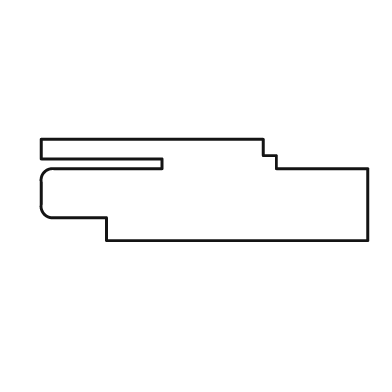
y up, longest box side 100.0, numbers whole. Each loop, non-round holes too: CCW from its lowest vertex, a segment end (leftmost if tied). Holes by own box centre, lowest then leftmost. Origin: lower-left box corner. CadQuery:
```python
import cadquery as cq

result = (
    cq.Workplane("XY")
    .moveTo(20.0, 0.0)
    .lineTo(100.0, 0.0)
    .lineTo(100.0, 22.0)
    .lineTo(72.0, 22.0)
    .lineTo(72.0, 26.0)
    .lineTo(68.0, 26.0)
    .lineTo(68.0, 31.0)
    .lineTo(0.0, 31.0)
    .lineTo(0.0, 25.0)
    .lineTo(37.0, 25.0)
    .lineTo(37.0, 22.0)
    .lineTo(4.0, 22.0)
    .threePointArc((1.0, 21.0), (0.0, 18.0))
    .lineTo(0.0, 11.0)
    .threePointArc((1.0, 8.0), (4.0, 7.0))
    .lineTo(20.0, 7.0)
    .close()
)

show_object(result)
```